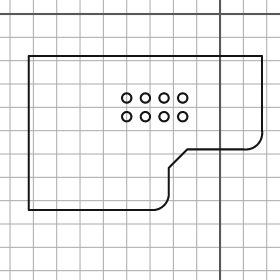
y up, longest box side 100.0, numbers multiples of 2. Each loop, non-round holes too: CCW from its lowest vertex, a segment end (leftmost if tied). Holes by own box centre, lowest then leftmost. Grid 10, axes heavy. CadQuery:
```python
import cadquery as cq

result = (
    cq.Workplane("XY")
    .moveTo(-82.0, -84.0)
    .lineTo(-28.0, -84.0)
    .threePointArc((-24.0, -82.0), (-22.0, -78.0))
    .lineTo(-22.0, -66.0)
    .lineTo(-14.0, -58.0)
    .lineTo(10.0, -58.0)
    .threePointArc((16.0, -56.0), (18.0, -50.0))
    .lineTo(18.0, -18.0)
    .lineTo(-82.0, -18.0)
    .close()
    .moveTo(-40.0, -44.0)
    .circle(2.0)
    .moveTo(-32.0, -44.0)
    .circle(2.0)
    .moveTo(-24.0, -44.0)
    .circle(2.0)
    .moveTo(-16.0, -44.0)
    .circle(2.0)
    .moveTo(-40.0, -36.0)
    .circle(2.0)
    .moveTo(-32.0, -36.0)
    .circle(2.0)
    .moveTo(-24.0, -36.0)
    .circle(2.0)
    .moveTo(-16.0, -36.0)
    .circle(2.0)
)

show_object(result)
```